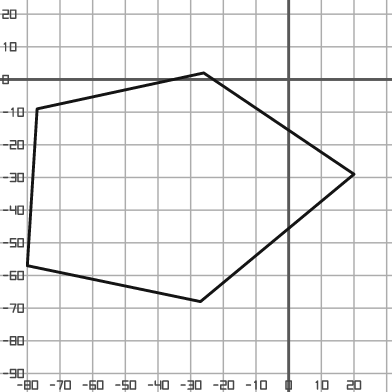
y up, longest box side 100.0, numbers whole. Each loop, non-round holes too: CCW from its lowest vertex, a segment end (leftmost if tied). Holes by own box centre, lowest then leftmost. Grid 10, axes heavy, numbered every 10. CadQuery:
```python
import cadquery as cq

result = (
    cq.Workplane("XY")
    .moveTo(-27.0, -68.0)
    .lineTo(20.0, -29.0)
    .lineTo(-26.0, 2.0)
    .lineTo(-77.0, -9.0)
    .lineTo(-80.0, -57.0)
    .close()
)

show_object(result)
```